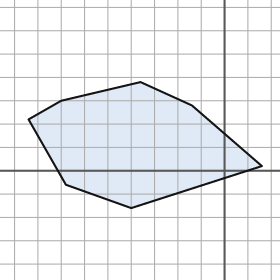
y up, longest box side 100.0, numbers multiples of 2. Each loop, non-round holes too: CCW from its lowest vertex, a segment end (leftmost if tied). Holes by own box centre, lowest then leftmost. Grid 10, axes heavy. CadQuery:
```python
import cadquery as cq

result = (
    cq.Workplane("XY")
    .moveTo(-40.0, -16.0)
    .lineTo(16.0, 2.0)
    .lineTo(-14.0, 28.0)
    .lineTo(-36.0, 38.0)
    .lineTo(-70.0, 30.0)
    .lineTo(-84.0, 22.0)
    .lineTo(-68.0, -6.0)
    .close()
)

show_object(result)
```